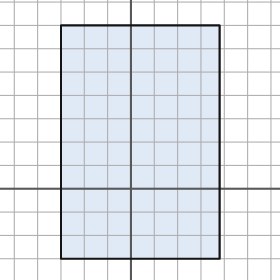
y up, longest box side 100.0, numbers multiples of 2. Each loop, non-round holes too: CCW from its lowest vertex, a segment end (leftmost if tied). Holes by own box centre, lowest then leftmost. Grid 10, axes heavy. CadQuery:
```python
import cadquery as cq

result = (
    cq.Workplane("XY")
    .moveTo(-30.0, -30.0)
    .lineTo(38.0, -30.0)
    .lineTo(38.0, 70.0)
    .lineTo(-30.0, 70.0)
    .close()
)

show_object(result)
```